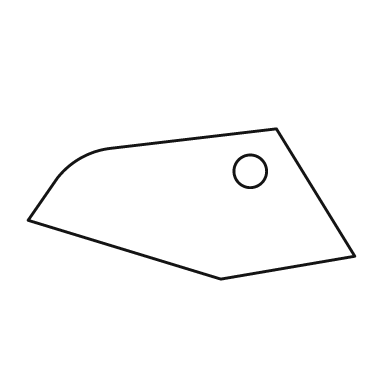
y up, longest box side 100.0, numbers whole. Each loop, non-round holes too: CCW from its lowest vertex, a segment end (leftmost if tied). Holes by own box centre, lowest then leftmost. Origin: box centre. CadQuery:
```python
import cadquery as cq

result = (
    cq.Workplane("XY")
    .moveTo(9.0, -23.0)
    .lineTo(50.0, -16.0)
    .lineTo(26.0, 23.0)
    .lineTo(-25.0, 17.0)
    .threePointArc((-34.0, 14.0), (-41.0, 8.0))
    .lineTo(-50.0, -5.0)
    .close()
    .moveTo(18.0, 10.0)
    .circle(5.0)
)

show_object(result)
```